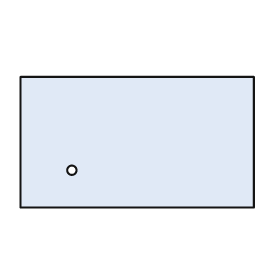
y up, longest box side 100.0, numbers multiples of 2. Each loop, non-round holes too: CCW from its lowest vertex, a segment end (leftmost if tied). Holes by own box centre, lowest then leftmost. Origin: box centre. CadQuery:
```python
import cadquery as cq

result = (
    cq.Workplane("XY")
    .moveTo(-50.0, -28.0)
    .lineTo(50.0, -28.0)
    .lineTo(50.0, 28.0)
    .lineTo(-50.0, 28.0)
    .close()
    .moveTo(-28.0, -12.0)
    .circle(2.0)
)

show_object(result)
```